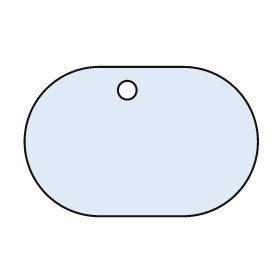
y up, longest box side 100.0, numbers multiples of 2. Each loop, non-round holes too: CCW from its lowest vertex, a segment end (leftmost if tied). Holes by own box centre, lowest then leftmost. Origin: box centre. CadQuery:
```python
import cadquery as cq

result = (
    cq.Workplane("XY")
    .moveTo(-18.0, -32.0)
    .lineTo(18.0, -32.0)
    .threePointArc((50.0, 0.0), (18.0, 32.0))
    .lineTo(-18.0, 32.0)
    .threePointArc((-50.0, 0.0), (-18.0, -32.0))
    .close()
    .moveTo(-6.0, 22.0)
    .circle(4.0)
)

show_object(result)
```